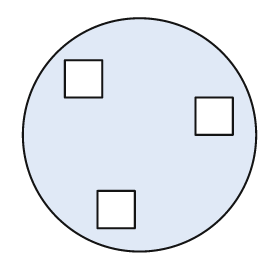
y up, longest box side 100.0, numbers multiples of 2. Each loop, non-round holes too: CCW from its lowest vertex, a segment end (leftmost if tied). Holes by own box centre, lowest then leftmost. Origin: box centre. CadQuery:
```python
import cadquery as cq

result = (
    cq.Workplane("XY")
    .moveTo(0.0, 0.0)
    .circle(50.0)
    .moveTo(-18.0, -40.0)
    .lineTo(-2.0, -40.0)
    .lineTo(-2.0, -24.0)
    .lineTo(-18.0, -24.0)
    .close()
    .moveTo(24.0, 0.0)
    .lineTo(40.0, 0.0)
    .lineTo(40.0, 16.0)
    .lineTo(24.0, 16.0)
    .close()
    .moveTo(-32.0, 16.0)
    .lineTo(-16.0, 16.0)
    .lineTo(-16.0, 32.0)
    .lineTo(-32.0, 32.0)
    .close()
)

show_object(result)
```